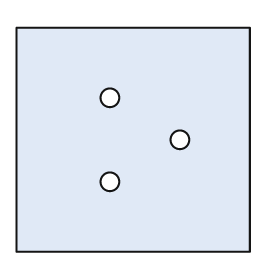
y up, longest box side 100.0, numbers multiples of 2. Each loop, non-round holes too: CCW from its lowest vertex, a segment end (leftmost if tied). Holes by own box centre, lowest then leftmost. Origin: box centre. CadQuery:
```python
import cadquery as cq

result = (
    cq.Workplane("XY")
    .moveTo(-50.0, -48.0)
    .lineTo(50.0, -48.0)
    .lineTo(50.0, 48.0)
    .lineTo(-50.0, 48.0)
    .close()
    .moveTo(-10.0, -18.0)
    .circle(4.0)
    .moveTo(20.0, 0.0)
    .circle(4.0)
    .moveTo(-10.0, 18.0)
    .circle(4.0)
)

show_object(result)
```